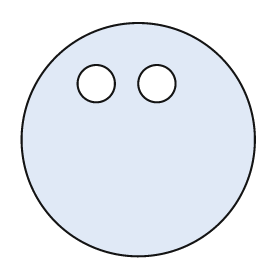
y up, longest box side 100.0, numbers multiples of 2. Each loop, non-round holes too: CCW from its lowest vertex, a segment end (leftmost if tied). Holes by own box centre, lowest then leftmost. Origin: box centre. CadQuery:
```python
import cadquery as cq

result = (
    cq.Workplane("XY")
    .moveTo(0.0, 0.0)
    .circle(50.0)
    .moveTo(-18.0, 24.0)
    .circle(8.0)
    .moveTo(8.0, 24.0)
    .circle(8.0)
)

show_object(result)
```